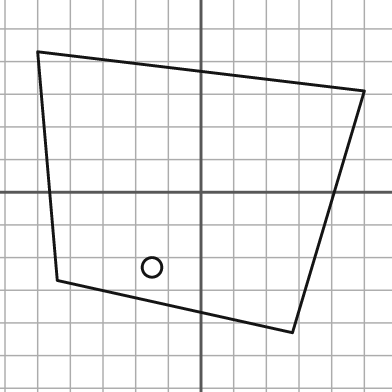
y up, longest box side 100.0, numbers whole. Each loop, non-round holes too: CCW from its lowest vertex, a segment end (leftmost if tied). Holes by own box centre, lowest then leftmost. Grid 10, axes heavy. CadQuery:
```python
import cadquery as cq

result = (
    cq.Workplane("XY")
    .moveTo(28.0, -43.0)
    .lineTo(50.0, 31.0)
    .lineTo(-50.0, 43.0)
    .lineTo(-44.0, -27.0)
    .close()
    .moveTo(-15.0, -23.0)
    .circle(3.0)
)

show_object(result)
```